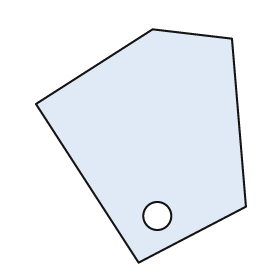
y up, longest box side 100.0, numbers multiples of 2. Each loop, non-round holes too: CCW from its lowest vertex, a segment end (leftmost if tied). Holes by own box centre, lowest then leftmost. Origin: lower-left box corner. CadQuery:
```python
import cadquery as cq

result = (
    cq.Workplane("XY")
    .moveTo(44.0, 0.0)
    .lineTo(90.0, 24.0)
    .lineTo(84.0, 96.0)
    .lineTo(50.0, 100.0)
    .lineTo(0.0, 68.0)
    .close()
    .moveTo(52.0, 20.0)
    .circle(6.0)
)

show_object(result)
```